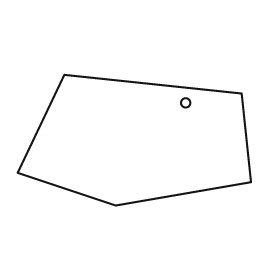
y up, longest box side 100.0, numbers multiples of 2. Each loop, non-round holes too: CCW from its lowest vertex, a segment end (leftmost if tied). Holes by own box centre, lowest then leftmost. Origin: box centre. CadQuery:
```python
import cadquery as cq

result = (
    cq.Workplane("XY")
    .moveTo(-8.0, -28.0)
    .lineTo(50.0, -18.0)
    .lineTo(46.0, 20.0)
    .lineTo(-30.0, 28.0)
    .lineTo(-50.0, -14.0)
    .close()
    .moveTo(22.0, 16.0)
    .circle(2.0)
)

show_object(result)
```